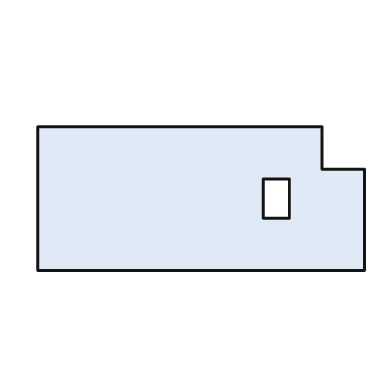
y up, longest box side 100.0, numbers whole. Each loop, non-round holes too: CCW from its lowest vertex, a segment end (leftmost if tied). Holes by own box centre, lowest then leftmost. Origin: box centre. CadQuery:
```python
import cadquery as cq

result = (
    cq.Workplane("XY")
    .moveTo(-50.0, -22.0)
    .lineTo(50.0, -22.0)
    .lineTo(50.0, 9.0)
    .lineTo(37.0, 9.0)
    .lineTo(37.0, 22.0)
    .lineTo(-50.0, 22.0)
    .close()
    .moveTo(19.0, -6.0)
    .lineTo(27.0, -6.0)
    .lineTo(27.0, 6.0)
    .lineTo(19.0, 6.0)
    .close()
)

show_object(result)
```